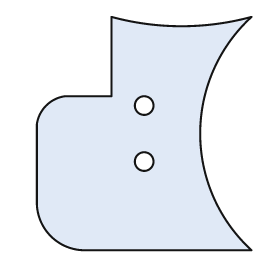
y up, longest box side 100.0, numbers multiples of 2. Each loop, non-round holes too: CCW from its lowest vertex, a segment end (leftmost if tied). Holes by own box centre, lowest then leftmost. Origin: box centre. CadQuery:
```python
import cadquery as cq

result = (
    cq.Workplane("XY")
    .moveTo(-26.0, -50.0)
    .lineTo(46.0, -50.0)
    .threePointArc((24.0, 0.0), (46.0, 50.0))
    .threePointArc((16.0, 46.0), (-14.0, 50.0))
    .lineTo(-14.0, 16.0)
    .lineTo(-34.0, 16.0)
    .threePointArc((-42.0, 12.0), (-46.0, 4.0))
    .lineTo(-46.0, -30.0)
    .threePointArc((-40.0, -44.0), (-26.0, -50.0))
    .close()
    .moveTo(0.0, -12.0)
    .circle(4.0)
    .moveTo(0.0, 12.0)
    .circle(4.0)
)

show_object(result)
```